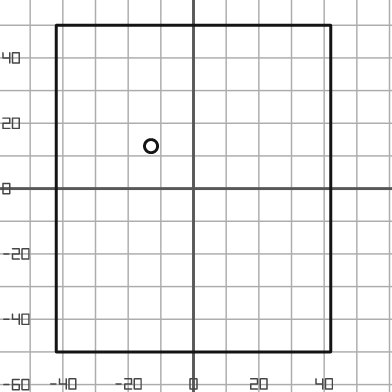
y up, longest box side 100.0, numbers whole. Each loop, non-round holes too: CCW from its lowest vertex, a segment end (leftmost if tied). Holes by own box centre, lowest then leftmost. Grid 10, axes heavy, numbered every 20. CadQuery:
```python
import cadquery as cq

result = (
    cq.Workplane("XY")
    .moveTo(-42.0, -50.0)
    .lineTo(42.0, -50.0)
    .lineTo(42.0, 50.0)
    .lineTo(-42.0, 50.0)
    .close()
    .moveTo(-13.0, 13.0)
    .circle(2.0)
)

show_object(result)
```